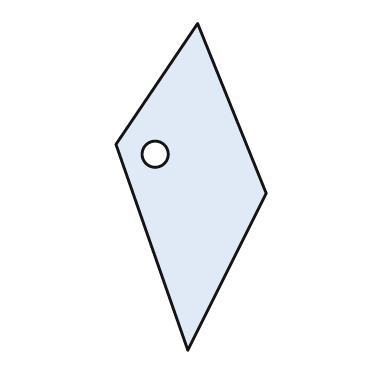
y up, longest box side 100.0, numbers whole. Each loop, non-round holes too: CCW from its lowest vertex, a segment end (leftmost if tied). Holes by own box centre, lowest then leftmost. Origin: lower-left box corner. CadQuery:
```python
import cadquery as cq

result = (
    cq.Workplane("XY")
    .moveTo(22.0, 0.0)
    .lineTo(46.0, 48.0)
    .lineTo(25.0, 100.0)
    .lineTo(0.0, 63.0)
    .close()
    .moveTo(12.0, 60.0)
    .circle(4.0)
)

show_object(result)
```